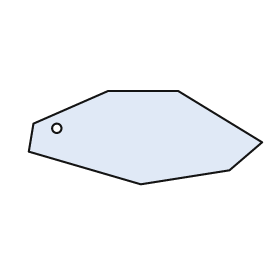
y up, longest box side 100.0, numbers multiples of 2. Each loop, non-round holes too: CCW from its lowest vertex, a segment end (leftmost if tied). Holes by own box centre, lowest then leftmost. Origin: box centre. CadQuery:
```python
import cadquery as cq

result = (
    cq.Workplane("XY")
    .moveTo(-2.0, -20.0)
    .lineTo(36.0, -14.0)
    .lineTo(50.0, -2.0)
    .lineTo(14.0, 20.0)
    .lineTo(-16.0, 20.0)
    .lineTo(-48.0, 6.0)
    .lineTo(-50.0, -6.0)
    .close()
    .moveTo(-38.0, 4.0)
    .circle(2.0)
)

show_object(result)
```